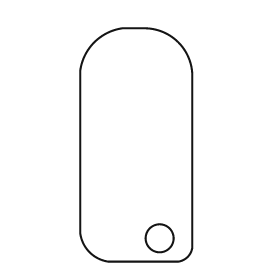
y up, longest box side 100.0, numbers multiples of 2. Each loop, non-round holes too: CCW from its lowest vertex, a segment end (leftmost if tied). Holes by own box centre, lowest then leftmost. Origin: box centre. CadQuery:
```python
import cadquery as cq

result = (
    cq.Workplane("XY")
    .moveTo(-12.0, -50.0)
    .lineTo(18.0, -50.0)
    .threePointArc((22.0, -48.0), (24.0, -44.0))
    .lineTo(24.0, 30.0)
    .threePointArc((18.0, 44.0), (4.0, 50.0))
    .lineTo(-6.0, 50.0)
    .threePointArc((-18.0, 44.0), (-24.0, 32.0))
    .lineTo(-24.0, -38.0)
    .threePointArc((-20.0, -46.0), (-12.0, -50.0))
    .close()
    .moveTo(10.0, -40.0)
    .circle(6.0)
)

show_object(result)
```